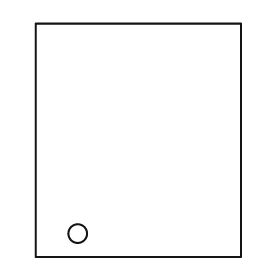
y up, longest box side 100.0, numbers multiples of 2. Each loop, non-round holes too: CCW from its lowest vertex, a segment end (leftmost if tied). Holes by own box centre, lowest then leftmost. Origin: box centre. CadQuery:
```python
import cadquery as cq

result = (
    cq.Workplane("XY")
    .moveTo(-44.0, -50.0)
    .lineTo(44.0, -50.0)
    .lineTo(44.0, 50.0)
    .lineTo(-44.0, 50.0)
    .close()
    .moveTo(-26.0, -40.0)
    .circle(4.0)
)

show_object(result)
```